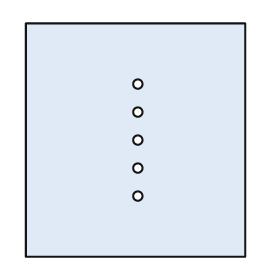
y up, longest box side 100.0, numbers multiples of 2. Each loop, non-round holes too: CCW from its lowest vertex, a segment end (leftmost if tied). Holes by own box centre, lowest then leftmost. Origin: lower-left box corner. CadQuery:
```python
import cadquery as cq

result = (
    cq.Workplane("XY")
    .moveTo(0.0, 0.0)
    .lineTo(94.0, 0.0)
    .lineTo(94.0, 100.0)
    .lineTo(0.0, 100.0)
    .close()
    .moveTo(48.0, 26.0)
    .circle(2.0)
    .moveTo(48.0, 38.0)
    .circle(2.0)
    .moveTo(48.0, 50.0)
    .circle(2.0)
    .moveTo(48.0, 62.0)
    .circle(2.0)
    .moveTo(48.0, 74.0)
    .circle(2.0)
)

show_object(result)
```